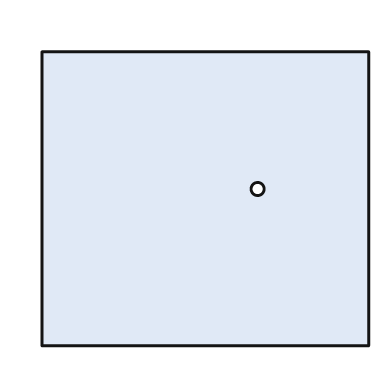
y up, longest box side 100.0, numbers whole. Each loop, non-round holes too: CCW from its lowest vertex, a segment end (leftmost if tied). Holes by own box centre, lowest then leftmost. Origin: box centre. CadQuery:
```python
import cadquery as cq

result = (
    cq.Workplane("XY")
    .moveTo(-50.0, -45.0)
    .lineTo(50.0, -45.0)
    .lineTo(50.0, 45.0)
    .lineTo(-50.0, 45.0)
    .close()
    .moveTo(16.0, 3.0)
    .circle(2.0)
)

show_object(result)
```